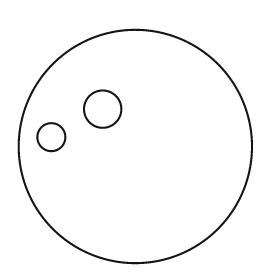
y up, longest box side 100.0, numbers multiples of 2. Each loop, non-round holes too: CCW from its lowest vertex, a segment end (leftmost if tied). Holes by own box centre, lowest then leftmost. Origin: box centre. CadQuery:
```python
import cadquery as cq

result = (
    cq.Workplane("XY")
    .moveTo(0.0, 0.0)
    .circle(50.0)
    .moveTo(-36.0, 4.0)
    .circle(6.0)
    .moveTo(-14.0, 16.0)
    .circle(8.0)
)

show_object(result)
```